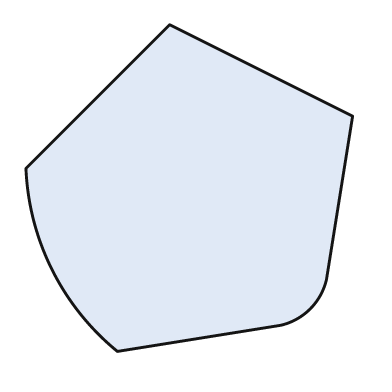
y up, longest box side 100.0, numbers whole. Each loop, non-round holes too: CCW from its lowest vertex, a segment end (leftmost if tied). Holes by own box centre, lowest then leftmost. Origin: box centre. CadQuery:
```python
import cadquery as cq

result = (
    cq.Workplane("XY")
    .moveTo(-22.0, -50.0)
    .lineTo(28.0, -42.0)
    .threePointArc((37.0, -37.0), (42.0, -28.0))
    .lineTo(50.0, 22.0)
    .lineTo(-6.0, 50.0)
    .lineTo(-50.0, 6.0)
    .threePointArc((-42.0, -25.0), (-22.0, -50.0))
    .close()
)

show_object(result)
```